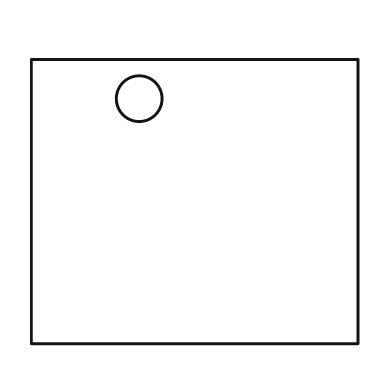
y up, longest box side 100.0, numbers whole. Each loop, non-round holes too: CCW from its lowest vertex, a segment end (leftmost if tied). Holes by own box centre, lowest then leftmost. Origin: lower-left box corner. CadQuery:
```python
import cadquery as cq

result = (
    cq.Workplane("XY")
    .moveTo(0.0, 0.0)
    .lineTo(100.0, 0.0)
    .lineTo(100.0, 87.0)
    .lineTo(0.0, 87.0)
    .close()
    .moveTo(33.0, 75.0)
    .circle(7.0)
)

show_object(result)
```